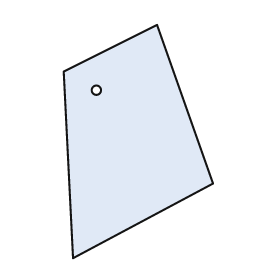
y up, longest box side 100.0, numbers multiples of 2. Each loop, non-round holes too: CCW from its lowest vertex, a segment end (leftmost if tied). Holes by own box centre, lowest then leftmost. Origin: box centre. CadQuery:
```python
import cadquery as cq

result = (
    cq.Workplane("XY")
    .moveTo(-28.0, -50.0)
    .lineTo(32.0, -18.0)
    .lineTo(8.0, 50.0)
    .lineTo(-32.0, 30.0)
    .close()
    .moveTo(-18.0, 22.0)
    .circle(2.0)
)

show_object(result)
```